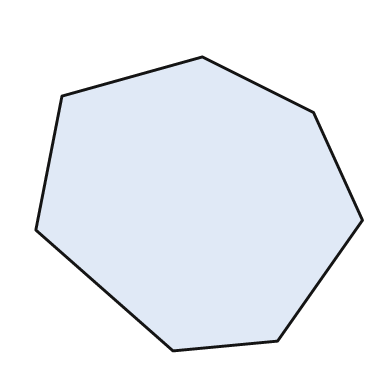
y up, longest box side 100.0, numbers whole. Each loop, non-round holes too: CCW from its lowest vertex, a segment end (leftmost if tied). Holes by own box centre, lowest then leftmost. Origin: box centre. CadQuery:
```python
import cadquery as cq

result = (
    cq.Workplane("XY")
    .moveTo(-8.0, -45.0)
    .lineTo(24.0, -42.0)
    .lineTo(50.0, -5.0)
    .lineTo(35.0, 28.0)
    .lineTo(1.0, 45.0)
    .lineTo(-42.0, 33.0)
    .lineTo(-50.0, -8.0)
    .close()
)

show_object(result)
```